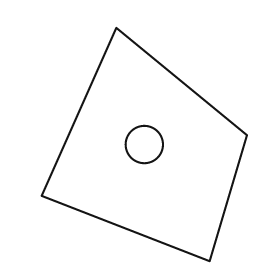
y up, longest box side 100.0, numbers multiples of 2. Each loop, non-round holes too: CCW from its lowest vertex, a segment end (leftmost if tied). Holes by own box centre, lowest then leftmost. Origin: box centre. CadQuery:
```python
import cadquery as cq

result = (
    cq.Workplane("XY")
    .moveTo(28.0, -50.0)
    .lineTo(44.0, 4.0)
    .lineTo(-12.0, 50.0)
    .lineTo(-44.0, -22.0)
    .close()
    .moveTo(0.0, 0.0)
    .circle(8.0)
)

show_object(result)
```